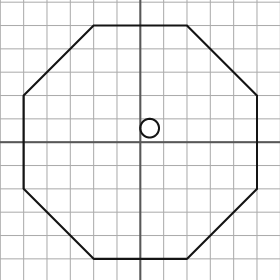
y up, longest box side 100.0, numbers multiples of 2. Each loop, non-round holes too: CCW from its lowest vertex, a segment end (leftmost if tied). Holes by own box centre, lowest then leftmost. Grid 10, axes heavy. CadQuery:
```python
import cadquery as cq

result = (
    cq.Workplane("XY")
    .moveTo(-20.0, -50.0)
    .lineTo(20.0, -50.0)
    .lineTo(50.0, -20.0)
    .lineTo(50.0, 20.0)
    .lineTo(20.0, 50.0)
    .lineTo(-20.0, 50.0)
    .lineTo(-50.0, 20.0)
    .lineTo(-50.0, -20.0)
    .close()
    .moveTo(4.0, 6.0)
    .circle(4.0)
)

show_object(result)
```